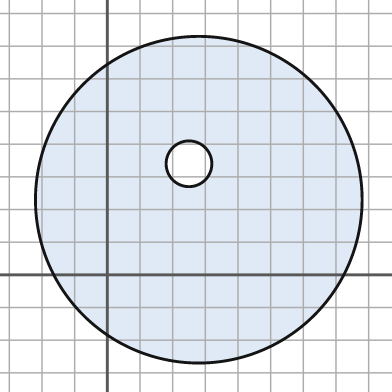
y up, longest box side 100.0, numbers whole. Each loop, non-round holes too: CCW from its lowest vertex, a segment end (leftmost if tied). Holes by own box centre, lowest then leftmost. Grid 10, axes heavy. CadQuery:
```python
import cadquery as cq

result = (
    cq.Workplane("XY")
    .moveTo(28.0, 23.0)
    .circle(50.0)
    .moveTo(25.0, 34.0)
    .circle(7.0)
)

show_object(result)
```